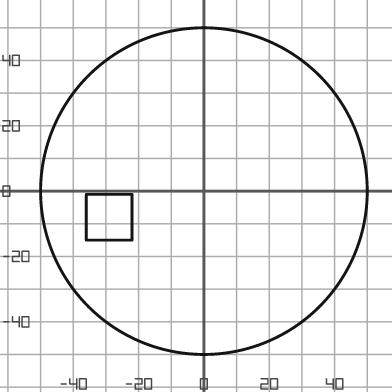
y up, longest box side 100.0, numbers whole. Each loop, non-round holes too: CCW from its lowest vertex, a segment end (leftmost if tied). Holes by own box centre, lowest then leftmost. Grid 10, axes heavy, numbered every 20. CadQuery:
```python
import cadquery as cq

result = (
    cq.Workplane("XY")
    .moveTo(0.0, 0.0)
    .circle(50.0)
    .moveTo(-36.0, -15.0)
    .lineTo(-22.0, -15.0)
    .lineTo(-22.0, -1.0)
    .lineTo(-36.0, -1.0)
    .close()
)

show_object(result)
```